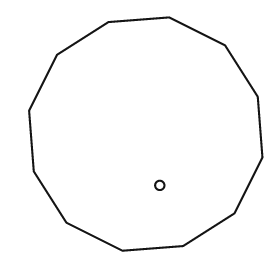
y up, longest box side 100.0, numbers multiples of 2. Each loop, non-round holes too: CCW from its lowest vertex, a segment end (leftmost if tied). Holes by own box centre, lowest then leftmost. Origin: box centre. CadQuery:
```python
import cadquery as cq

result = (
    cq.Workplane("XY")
    .moveTo(-10.0, -50.0)
    .lineTo(16.0, -48.0)
    .lineTo(38.0, -34.0)
    .lineTo(50.0, -10.0)
    .lineTo(48.0, 16.0)
    .lineTo(34.0, 38.0)
    .lineTo(10.0, 50.0)
    .lineTo(-16.0, 48.0)
    .lineTo(-38.0, 34.0)
    .lineTo(-50.0, 10.0)
    .lineTo(-48.0, -16.0)
    .lineTo(-34.0, -38.0)
    .close()
    .moveTo(6.0, -22.0)
    .circle(2.0)
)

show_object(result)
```